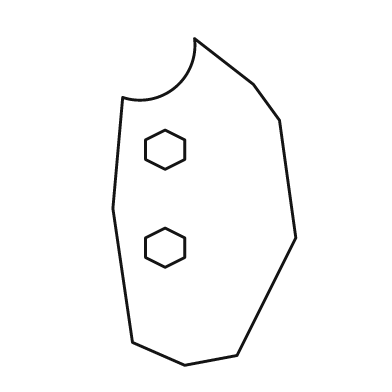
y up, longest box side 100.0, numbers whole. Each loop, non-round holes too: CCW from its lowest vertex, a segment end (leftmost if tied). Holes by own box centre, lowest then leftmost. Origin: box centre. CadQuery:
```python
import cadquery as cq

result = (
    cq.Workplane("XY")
    .moveTo(-6.0, -50.0)
    .lineTo(10.0, -47.0)
    .lineTo(28.0, -11.0)
    .lineTo(23.0, 25.0)
    .lineTo(15.0, 36.0)
    .lineTo(-3.0, 50.0)
    .threePointArc((-9.0, 35.0), (-25.0, 32.0))
    .lineTo(-28.0, -2.0)
    .lineTo(-22.0, -43.0)
    .close()
    .moveTo(-12.0, -20.0)
    .lineTo(-6.0, -17.0)
    .lineTo(-6.0, -11.0)
    .lineTo(-12.0, -8.0)
    .lineTo(-18.0, -11.0)
    .lineTo(-18.0, -17.0)
    .close()
    .moveTo(-12.0, 10.0)
    .lineTo(-6.0, 13.0)
    .lineTo(-6.0, 19.0)
    .lineTo(-12.0, 22.0)
    .lineTo(-18.0, 19.0)
    .lineTo(-18.0, 13.0)
    .close()
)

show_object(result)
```